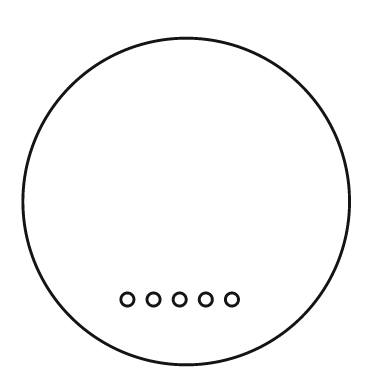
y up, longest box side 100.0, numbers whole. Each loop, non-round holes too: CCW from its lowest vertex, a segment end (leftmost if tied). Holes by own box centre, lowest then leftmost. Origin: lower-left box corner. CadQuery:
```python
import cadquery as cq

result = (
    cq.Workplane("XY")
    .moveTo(50.0, 50.0)
    .circle(50.0)
    .moveTo(32.0, 20.0)
    .circle(2.0)
    .moveTo(40.0, 20.0)
    .circle(2.0)
    .moveTo(48.0, 20.0)
    .circle(2.0)
    .moveTo(56.0, 20.0)
    .circle(2.0)
    .moveTo(64.0, 20.0)
    .circle(2.0)
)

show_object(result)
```